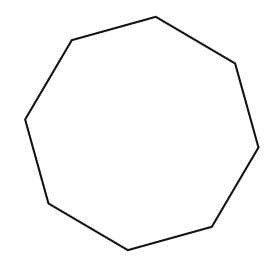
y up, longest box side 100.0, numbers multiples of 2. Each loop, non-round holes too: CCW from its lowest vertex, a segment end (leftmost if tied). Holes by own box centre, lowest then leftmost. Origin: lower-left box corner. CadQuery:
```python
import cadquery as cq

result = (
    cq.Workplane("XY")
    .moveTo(44.0, 0.0)
    .lineTo(80.0, 10.0)
    .lineTo(100.0, 44.0)
    .lineTo(90.0, 80.0)
    .lineTo(56.0, 100.0)
    .lineTo(20.0, 90.0)
    .lineTo(0.0, 56.0)
    .lineTo(10.0, 20.0)
    .close()
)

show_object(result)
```